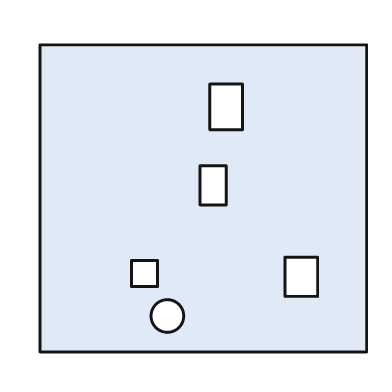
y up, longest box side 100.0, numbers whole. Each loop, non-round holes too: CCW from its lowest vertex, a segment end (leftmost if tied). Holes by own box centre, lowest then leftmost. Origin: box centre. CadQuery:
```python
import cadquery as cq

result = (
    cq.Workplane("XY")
    .moveTo(-50.0, -47.0)
    .lineTo(50.0, -47.0)
    .lineTo(50.0, 47.0)
    .lineTo(-50.0, 47.0)
    .close()
    .moveTo(-11.0, -36.0)
    .circle(5.0)
    .moveTo(25.0, -30.0)
    .lineTo(35.0, -30.0)
    .lineTo(35.0, -18.0)
    .lineTo(25.0, -18.0)
    .close()
    .moveTo(-22.0, -27.0)
    .lineTo(-14.0, -27.0)
    .lineTo(-14.0, -19.0)
    .lineTo(-22.0, -19.0)
    .close()
    .moveTo(-1.0, -2.0)
    .lineTo(7.0, -2.0)
    .lineTo(7.0, 10.0)
    .lineTo(-1.0, 10.0)
    .close()
    .moveTo(2.0, 21.0)
    .lineTo(12.0, 21.0)
    .lineTo(12.0, 35.0)
    .lineTo(2.0, 35.0)
    .close()
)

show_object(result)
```